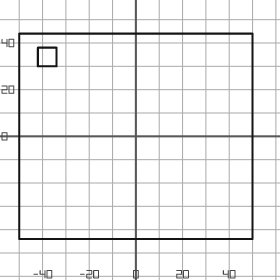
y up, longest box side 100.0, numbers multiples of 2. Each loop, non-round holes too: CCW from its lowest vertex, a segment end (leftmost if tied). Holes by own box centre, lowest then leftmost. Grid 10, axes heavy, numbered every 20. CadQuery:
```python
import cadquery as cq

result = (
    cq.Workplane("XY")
    .moveTo(-50.0, -44.0)
    .lineTo(50.0, -44.0)
    .lineTo(50.0, 44.0)
    .lineTo(-50.0, 44.0)
    .close()
    .moveTo(-42.0, 30.0)
    .lineTo(-34.0, 30.0)
    .lineTo(-34.0, 38.0)
    .lineTo(-42.0, 38.0)
    .close()
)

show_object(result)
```